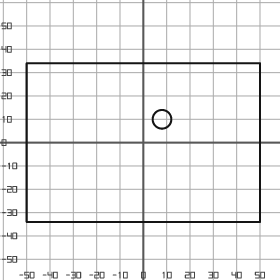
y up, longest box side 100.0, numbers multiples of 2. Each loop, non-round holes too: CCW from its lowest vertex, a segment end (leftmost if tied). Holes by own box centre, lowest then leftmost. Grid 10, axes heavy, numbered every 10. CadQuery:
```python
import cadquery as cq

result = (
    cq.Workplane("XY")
    .moveTo(-50.0, -34.0)
    .lineTo(50.0, -34.0)
    .lineTo(50.0, 34.0)
    .lineTo(-50.0, 34.0)
    .close()
    .moveTo(8.0, 10.0)
    .circle(4.0)
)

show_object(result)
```